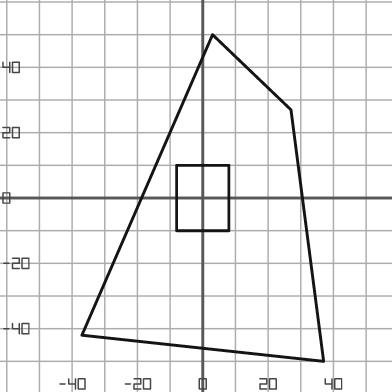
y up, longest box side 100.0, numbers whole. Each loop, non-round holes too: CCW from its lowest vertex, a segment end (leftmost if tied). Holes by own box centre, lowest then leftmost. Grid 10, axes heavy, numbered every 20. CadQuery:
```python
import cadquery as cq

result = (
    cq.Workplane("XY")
    .moveTo(37.0, -50.0)
    .lineTo(27.0, 27.0)
    .lineTo(3.0, 50.0)
    .lineTo(-37.0, -42.0)
    .close()
    .moveTo(-8.0, -10.0)
    .lineTo(8.0, -10.0)
    .lineTo(8.0, 10.0)
    .lineTo(-8.0, 10.0)
    .close()
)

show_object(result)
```